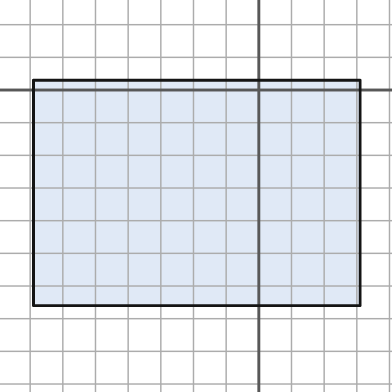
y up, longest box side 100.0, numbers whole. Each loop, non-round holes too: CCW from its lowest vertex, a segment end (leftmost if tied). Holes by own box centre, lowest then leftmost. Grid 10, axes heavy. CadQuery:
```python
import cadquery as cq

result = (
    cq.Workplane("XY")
    .moveTo(-69.0, -66.0)
    .lineTo(31.0, -66.0)
    .lineTo(31.0, 3.0)
    .lineTo(-69.0, 3.0)
    .close()
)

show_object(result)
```